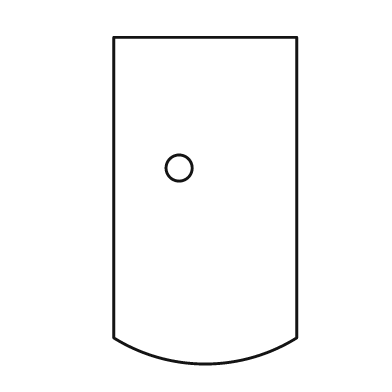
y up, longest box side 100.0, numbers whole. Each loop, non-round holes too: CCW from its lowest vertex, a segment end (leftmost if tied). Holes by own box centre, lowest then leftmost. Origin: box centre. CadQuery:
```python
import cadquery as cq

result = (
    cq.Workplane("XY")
    .moveTo(-28.0, -42.0)
    .threePointArc((0.0, -50.0), (28.0, -42.0))
    .lineTo(28.0, 50.0)
    .lineTo(-28.0, 50.0)
    .close()
    .moveTo(-8.0, 10.0)
    .circle(4.0)
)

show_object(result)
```